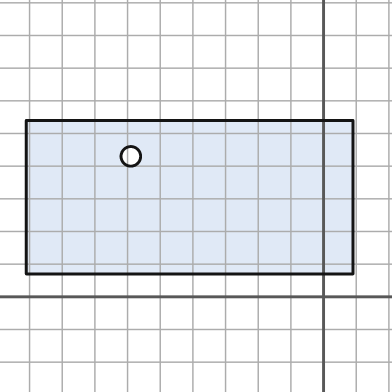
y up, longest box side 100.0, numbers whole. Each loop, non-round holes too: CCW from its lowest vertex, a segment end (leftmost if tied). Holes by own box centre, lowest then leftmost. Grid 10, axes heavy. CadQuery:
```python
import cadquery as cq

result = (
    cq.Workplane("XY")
    .moveTo(-91.0, 7.0)
    .lineTo(9.0, 7.0)
    .lineTo(9.0, 54.0)
    .lineTo(-91.0, 54.0)
    .close()
    .moveTo(-59.0, 43.0)
    .circle(3.0)
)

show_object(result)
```